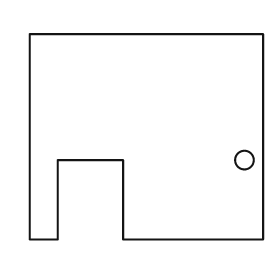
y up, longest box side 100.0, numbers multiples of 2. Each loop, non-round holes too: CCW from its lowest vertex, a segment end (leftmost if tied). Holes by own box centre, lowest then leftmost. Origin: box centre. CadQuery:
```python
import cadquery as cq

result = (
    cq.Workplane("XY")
    .moveTo(-50.0, -44.0)
    .lineTo(-38.0, -44.0)
    .lineTo(-38.0, -10.0)
    .lineTo(-10.0, -10.0)
    .lineTo(-10.0, -44.0)
    .lineTo(50.0, -44.0)
    .lineTo(50.0, 44.0)
    .lineTo(-50.0, 44.0)
    .close()
    .moveTo(42.0, -10.0)
    .circle(4.0)
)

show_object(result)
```